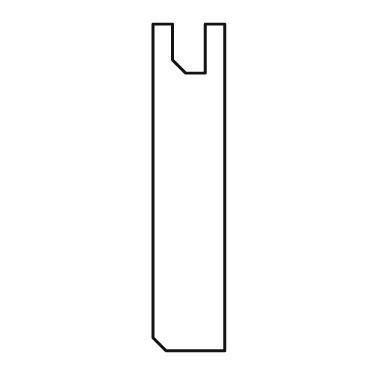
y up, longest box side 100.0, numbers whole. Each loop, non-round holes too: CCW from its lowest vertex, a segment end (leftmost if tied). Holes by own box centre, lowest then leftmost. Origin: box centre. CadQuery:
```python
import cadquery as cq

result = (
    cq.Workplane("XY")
    .moveTo(-7.0, -50.0)
    .lineTo(11.0, -50.0)
    .lineTo(11.0, 50.0)
    .lineTo(5.0, 50.0)
    .lineTo(5.0, 35.0)
    .lineTo(-1.0, 35.0)
    .lineTo(-5.0, 39.0)
    .lineTo(-5.0, 50.0)
    .lineTo(-11.0, 50.0)
    .lineTo(-11.0, -46.0)
    .close()
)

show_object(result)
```